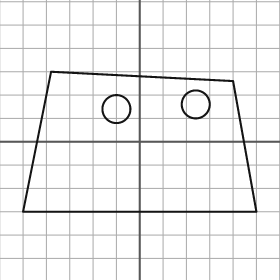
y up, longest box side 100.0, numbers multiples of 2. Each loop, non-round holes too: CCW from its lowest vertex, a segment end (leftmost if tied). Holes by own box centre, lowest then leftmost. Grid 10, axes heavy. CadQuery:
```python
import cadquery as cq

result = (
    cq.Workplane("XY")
    .moveTo(-50.0, -30.0)
    .lineTo(50.0, -30.0)
    .lineTo(40.0, 26.0)
    .lineTo(-38.0, 30.0)
    .close()
    .moveTo(-10.0, 14.0)
    .circle(6.0)
    .moveTo(24.0, 16.0)
    .circle(6.0)
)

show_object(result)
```